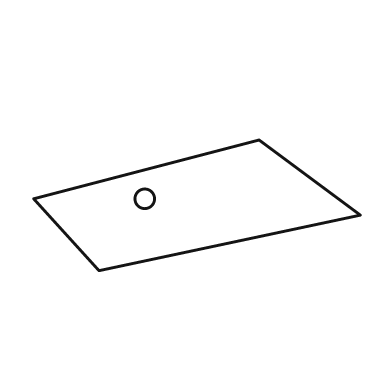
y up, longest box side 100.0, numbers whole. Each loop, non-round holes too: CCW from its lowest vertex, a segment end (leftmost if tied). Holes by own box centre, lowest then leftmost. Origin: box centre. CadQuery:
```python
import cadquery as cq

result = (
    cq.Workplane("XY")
    .moveTo(-30.0, -20.0)
    .lineTo(50.0, -3.0)
    .lineTo(19.0, 20.0)
    .lineTo(-50.0, 2.0)
    .close()
    .moveTo(-16.0, 2.0)
    .circle(3.0)
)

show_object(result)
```